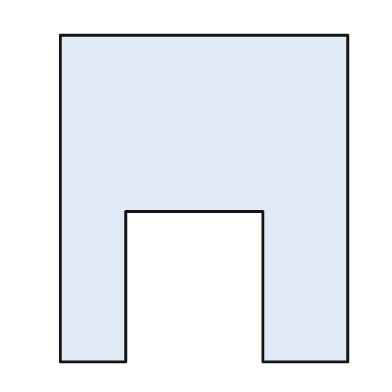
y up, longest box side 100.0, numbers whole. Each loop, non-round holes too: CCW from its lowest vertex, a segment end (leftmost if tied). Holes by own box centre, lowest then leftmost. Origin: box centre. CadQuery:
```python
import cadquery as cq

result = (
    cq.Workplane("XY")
    .moveTo(-44.0, -50.0)
    .lineTo(-24.0, -50.0)
    .lineTo(-24.0, -4.0)
    .lineTo(18.0, -4.0)
    .lineTo(18.0, -50.0)
    .lineTo(44.0, -50.0)
    .lineTo(44.0, 50.0)
    .lineTo(-44.0, 50.0)
    .close()
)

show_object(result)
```